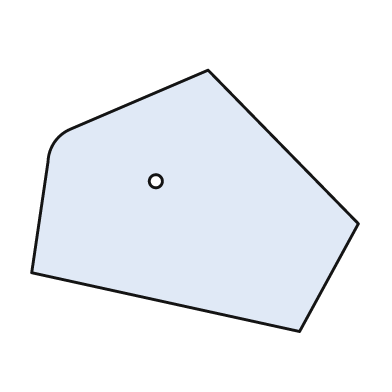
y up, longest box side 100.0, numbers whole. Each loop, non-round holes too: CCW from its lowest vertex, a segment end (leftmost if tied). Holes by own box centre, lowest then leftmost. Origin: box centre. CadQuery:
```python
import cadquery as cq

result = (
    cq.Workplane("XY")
    .moveTo(32.0, -40.0)
    .lineTo(50.0, -7.0)
    .lineTo(4.0, 40.0)
    .lineTo(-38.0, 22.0)
    .threePointArc((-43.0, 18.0), (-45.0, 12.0))
    .lineTo(-50.0, -22.0)
    .close()
    .moveTo(-12.0, 6.0)
    .circle(2.0)
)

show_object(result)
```